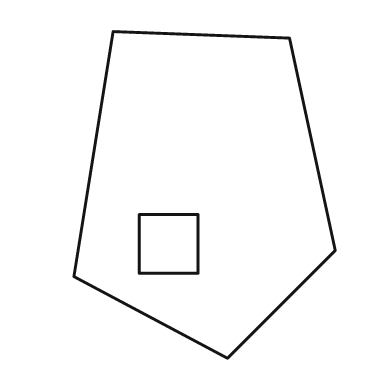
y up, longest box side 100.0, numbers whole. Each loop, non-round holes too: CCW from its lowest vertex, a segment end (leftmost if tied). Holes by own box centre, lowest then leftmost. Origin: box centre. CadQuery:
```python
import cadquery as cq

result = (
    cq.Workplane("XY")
    .moveTo(7.0, -50.0)
    .lineTo(40.0, -17.0)
    .lineTo(26.0, 48.0)
    .lineTo(-28.0, 50.0)
    .lineTo(-40.0, -25.0)
    .close()
    .moveTo(-20.0, -24.0)
    .lineTo(-2.0, -24.0)
    .lineTo(-2.0, -6.0)
    .lineTo(-20.0, -6.0)
    .close()
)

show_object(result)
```